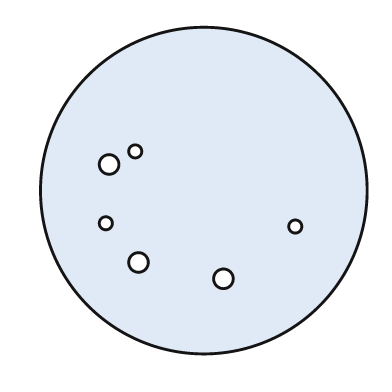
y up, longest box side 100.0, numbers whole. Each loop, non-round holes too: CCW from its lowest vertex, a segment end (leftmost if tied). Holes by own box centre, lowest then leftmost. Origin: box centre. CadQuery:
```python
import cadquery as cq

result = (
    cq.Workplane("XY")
    .moveTo(0.0, 0.0)
    .circle(50.0)
    .moveTo(6.0, -27.0)
    .circle(3.0)
    .moveTo(-20.0, -22.0)
    .circle(3.0)
    .moveTo(28.0, -11.0)
    .circle(2.0)
    .moveTo(-30.0, -10.0)
    .circle(2.0)
    .moveTo(-29.0, 8.0)
    .circle(3.0)
    .moveTo(-21.0, 12.0)
    .circle(2.0)
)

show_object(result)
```